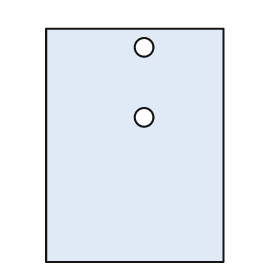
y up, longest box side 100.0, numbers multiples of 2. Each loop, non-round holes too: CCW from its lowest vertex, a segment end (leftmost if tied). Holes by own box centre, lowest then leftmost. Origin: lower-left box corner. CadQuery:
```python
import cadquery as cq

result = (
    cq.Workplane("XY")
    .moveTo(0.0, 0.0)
    .lineTo(76.0, 0.0)
    .lineTo(76.0, 100.0)
    .lineTo(0.0, 100.0)
    .close()
    .moveTo(42.0, 62.0)
    .circle(4.0)
    .moveTo(42.0, 92.0)
    .circle(4.0)
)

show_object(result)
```